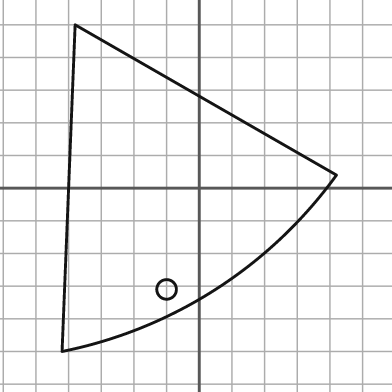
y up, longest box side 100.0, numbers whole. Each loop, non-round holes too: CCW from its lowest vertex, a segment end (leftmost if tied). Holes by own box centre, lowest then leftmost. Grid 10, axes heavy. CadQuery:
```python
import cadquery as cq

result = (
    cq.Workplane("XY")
    .moveTo(-42.0, -50.0)
    .threePointArc((5.0, -31.0), (42.0, 4.0))
    .lineTo(-38.0, 50.0)
    .close()
    .moveTo(-10.0, -31.0)
    .circle(3.0)
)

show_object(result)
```